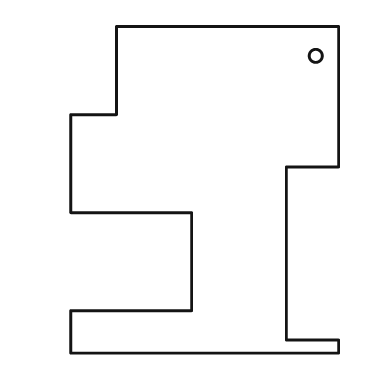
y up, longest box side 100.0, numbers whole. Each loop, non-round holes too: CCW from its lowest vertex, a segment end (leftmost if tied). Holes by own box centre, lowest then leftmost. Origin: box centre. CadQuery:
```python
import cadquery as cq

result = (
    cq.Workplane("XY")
    .moveTo(-41.0, -50.0)
    .lineTo(41.0, -50.0)
    .lineTo(41.0, -46.0)
    .lineTo(25.0, -46.0)
    .lineTo(25.0, 7.0)
    .lineTo(41.0, 7.0)
    .lineTo(41.0, 50.0)
    .lineTo(-27.0, 50.0)
    .lineTo(-27.0, 23.0)
    .lineTo(-41.0, 23.0)
    .lineTo(-41.0, -7.0)
    .lineTo(-4.0, -7.0)
    .lineTo(-4.0, -37.0)
    .lineTo(-41.0, -37.0)
    .close()
    .moveTo(34.0, 41.0)
    .circle(2.0)
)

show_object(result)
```